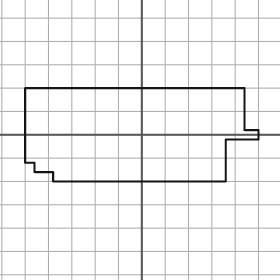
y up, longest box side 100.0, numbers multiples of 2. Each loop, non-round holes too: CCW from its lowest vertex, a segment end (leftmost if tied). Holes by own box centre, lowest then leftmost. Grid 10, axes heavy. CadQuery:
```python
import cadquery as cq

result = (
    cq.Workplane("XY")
    .moveTo(-38.0, -20.0)
    .lineTo(36.0, -20.0)
    .lineTo(36.0, -2.0)
    .lineTo(50.0, -2.0)
    .lineTo(50.0, 2.0)
    .lineTo(44.0, 2.0)
    .lineTo(44.0, 20.0)
    .lineTo(-50.0, 20.0)
    .lineTo(-50.0, -12.0)
    .lineTo(-46.0, -12.0)
    .lineTo(-46.0, -16.0)
    .lineTo(-38.0, -16.0)
    .close()
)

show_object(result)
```